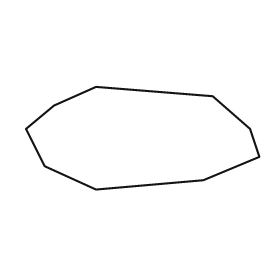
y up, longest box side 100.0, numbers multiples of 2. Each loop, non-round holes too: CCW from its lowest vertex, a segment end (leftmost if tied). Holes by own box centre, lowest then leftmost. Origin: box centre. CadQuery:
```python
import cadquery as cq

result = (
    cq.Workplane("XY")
    .moveTo(-20.0, -22.0)
    .lineTo(26.0, -18.0)
    .lineTo(50.0, -8.0)
    .lineTo(46.0, 4.0)
    .lineTo(30.0, 18.0)
    .lineTo(-20.0, 22.0)
    .lineTo(-38.0, 14.0)
    .lineTo(-50.0, 4.0)
    .lineTo(-42.0, -12.0)
    .close()
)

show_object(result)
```